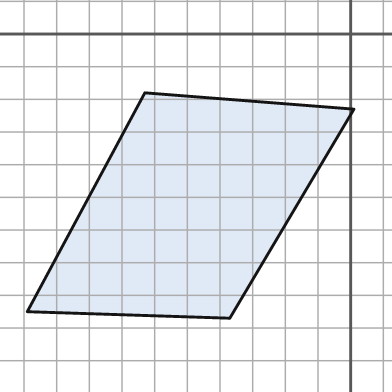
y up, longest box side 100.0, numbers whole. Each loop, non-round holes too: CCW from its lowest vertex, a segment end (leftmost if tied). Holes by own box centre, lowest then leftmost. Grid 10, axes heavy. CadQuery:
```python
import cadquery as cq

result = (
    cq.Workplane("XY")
    .moveTo(-37.0, -87.0)
    .lineTo(1.0, -23.0)
    .lineTo(-63.0, -18.0)
    .lineTo(-99.0, -85.0)
    .close()
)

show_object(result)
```